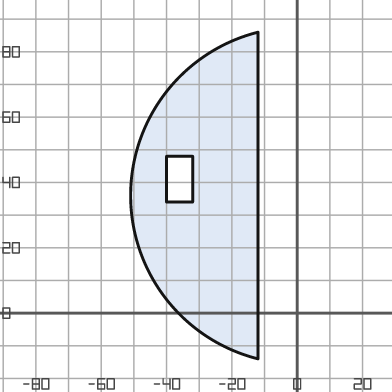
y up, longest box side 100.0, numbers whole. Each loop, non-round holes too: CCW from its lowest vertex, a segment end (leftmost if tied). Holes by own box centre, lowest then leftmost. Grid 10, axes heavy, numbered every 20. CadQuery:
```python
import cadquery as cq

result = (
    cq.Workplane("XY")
    .moveTo(-12.0, -14.0)
    .lineTo(-12.0, 86.0)
    .threePointArc((-51.0, 36.0), (-12.0, -14.0))
    .close()
    .moveTo(-40.0, 34.0)
    .lineTo(-32.0, 34.0)
    .lineTo(-32.0, 48.0)
    .lineTo(-40.0, 48.0)
    .close()
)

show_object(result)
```